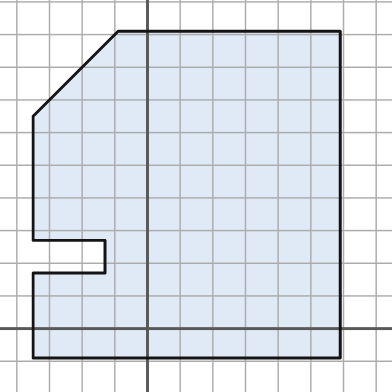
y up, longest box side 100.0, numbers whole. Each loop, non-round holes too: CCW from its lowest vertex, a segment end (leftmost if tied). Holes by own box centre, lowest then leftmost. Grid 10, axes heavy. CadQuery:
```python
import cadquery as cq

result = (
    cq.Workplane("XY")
    .moveTo(-35.0, -9.0)
    .lineTo(59.0, -9.0)
    .lineTo(59.0, 91.0)
    .lineTo(-9.0, 91.0)
    .lineTo(-35.0, 65.0)
    .lineTo(-35.0, 27.0)
    .lineTo(-13.0, 27.0)
    .lineTo(-13.0, 17.0)
    .lineTo(-35.0, 17.0)
    .close()
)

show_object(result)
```